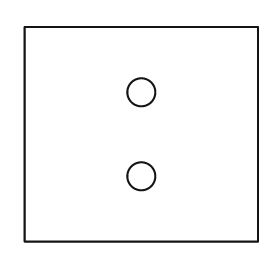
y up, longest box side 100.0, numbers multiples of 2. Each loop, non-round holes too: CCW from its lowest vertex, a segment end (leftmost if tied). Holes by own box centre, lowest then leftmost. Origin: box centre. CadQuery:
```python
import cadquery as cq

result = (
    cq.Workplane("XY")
    .moveTo(-50.0, -46.0)
    .lineTo(50.0, -46.0)
    .lineTo(50.0, 46.0)
    .lineTo(-50.0, 46.0)
    .close()
    .moveTo(0.0, -18.0)
    .circle(6.0)
    .moveTo(0.0, 18.0)
    .circle(6.0)
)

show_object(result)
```